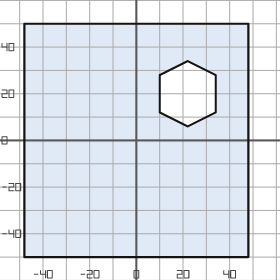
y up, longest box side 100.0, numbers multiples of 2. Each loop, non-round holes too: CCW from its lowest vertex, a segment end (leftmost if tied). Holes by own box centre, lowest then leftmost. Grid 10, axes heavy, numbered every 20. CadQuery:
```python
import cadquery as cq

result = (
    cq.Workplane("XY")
    .moveTo(-48.0, -50.0)
    .lineTo(48.0, -50.0)
    .lineTo(48.0, 50.0)
    .lineTo(-48.0, 50.0)
    .close()
    .moveTo(22.0, 6.0)
    .lineTo(34.0, 12.0)
    .lineTo(34.0, 28.0)
    .lineTo(22.0, 34.0)
    .lineTo(10.0, 28.0)
    .lineTo(10.0, 12.0)
    .close()
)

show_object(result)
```